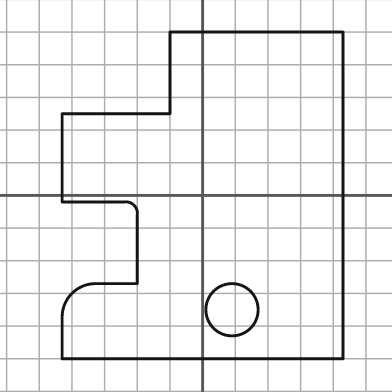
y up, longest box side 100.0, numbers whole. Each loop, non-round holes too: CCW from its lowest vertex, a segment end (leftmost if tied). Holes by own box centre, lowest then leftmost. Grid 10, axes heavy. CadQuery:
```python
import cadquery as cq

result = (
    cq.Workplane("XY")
    .moveTo(-43.0, -50.0)
    .lineTo(43.0, -50.0)
    .lineTo(43.0, 50.0)
    .lineTo(-10.0, 50.0)
    .lineTo(-10.0, 25.0)
    .lineTo(-43.0, 25.0)
    .lineTo(-43.0, -2.0)
    .lineTo(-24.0, -2.0)
    .threePointArc((-21.0, -3.0), (-20.0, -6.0))
    .lineTo(-20.0, -27.0)
    .lineTo(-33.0, -27.0)
    .threePointArc((-40.0, -30.0), (-43.0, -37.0))
    .close()
    .moveTo(9.0, -35.0)
    .circle(8.0)
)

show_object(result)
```